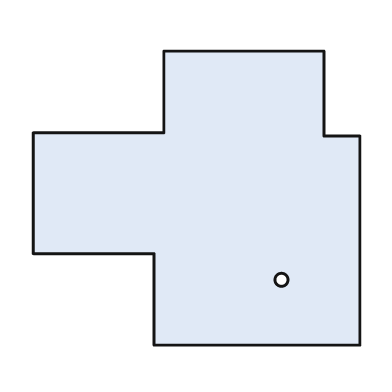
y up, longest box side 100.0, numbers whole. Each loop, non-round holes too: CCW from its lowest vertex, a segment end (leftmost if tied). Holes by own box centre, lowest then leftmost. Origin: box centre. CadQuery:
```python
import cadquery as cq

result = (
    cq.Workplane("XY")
    .moveTo(-13.0, -45.0)
    .lineTo(50.0, -45.0)
    .lineTo(50.0, 19.0)
    .lineTo(39.0, 19.0)
    .lineTo(39.0, 45.0)
    .lineTo(-10.0, 45.0)
    .lineTo(-10.0, 20.0)
    .lineTo(-50.0, 20.0)
    .lineTo(-50.0, -17.0)
    .lineTo(-13.0, -17.0)
    .close()
    .moveTo(26.0, -25.0)
    .circle(2.0)
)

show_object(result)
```